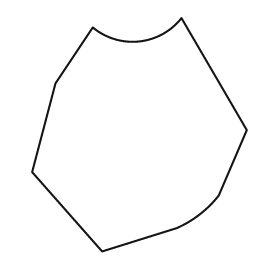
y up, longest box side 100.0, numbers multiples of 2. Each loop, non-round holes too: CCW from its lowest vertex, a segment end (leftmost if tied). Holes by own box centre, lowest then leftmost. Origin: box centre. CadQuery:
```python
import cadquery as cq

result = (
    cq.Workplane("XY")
    .moveTo(-16.0, -50.0)
    .lineTo(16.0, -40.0)
    .threePointArc((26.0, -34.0), (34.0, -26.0))
    .lineTo(46.0, 2.0)
    .lineTo(18.0, 50.0)
    .threePointArc((0.0, 40.0), (-20.0, 46.0))
    .lineTo(-36.0, 22.0)
    .lineTo(-46.0, -16.0)
    .close()
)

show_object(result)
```